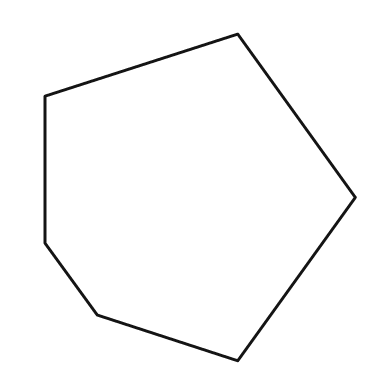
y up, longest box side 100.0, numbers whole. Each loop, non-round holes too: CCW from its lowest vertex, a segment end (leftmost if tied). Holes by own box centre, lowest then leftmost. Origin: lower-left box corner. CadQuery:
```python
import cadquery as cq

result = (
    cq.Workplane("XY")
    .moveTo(59.0, 0.0)
    .lineTo(95.0, 50.0)
    .lineTo(59.0, 100.0)
    .lineTo(0.0, 81.0)
    .lineTo(0.0, 36.0)
    .lineTo(16.0, 14.0)
    .close()
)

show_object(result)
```